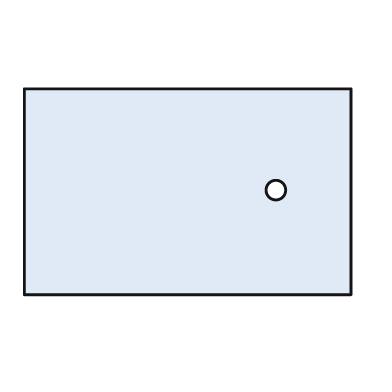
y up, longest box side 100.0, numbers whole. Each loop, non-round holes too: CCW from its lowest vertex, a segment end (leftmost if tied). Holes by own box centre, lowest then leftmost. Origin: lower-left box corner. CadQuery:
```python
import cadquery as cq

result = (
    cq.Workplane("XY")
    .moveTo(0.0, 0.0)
    .lineTo(100.0, 0.0)
    .lineTo(100.0, 63.0)
    .lineTo(0.0, 63.0)
    .close()
    .moveTo(77.0, 32.0)
    .circle(3.0)
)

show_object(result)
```